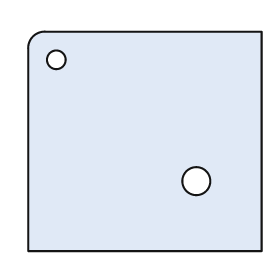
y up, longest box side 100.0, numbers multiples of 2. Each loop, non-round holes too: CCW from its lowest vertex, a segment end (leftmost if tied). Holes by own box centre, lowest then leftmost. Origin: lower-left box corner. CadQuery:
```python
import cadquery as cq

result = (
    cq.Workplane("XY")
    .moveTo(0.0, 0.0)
    .lineTo(100.0, 0.0)
    .lineTo(100.0, 94.0)
    .lineTo(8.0, 94.0)
    .threePointArc((2.0, 92.0), (0.0, 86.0))
    .close()
    .moveTo(72.0, 30.0)
    .circle(6.0)
    .moveTo(12.0, 82.0)
    .circle(4.0)
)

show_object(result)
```